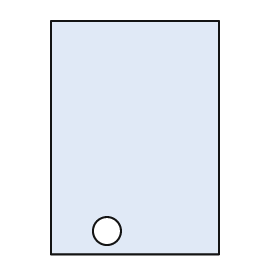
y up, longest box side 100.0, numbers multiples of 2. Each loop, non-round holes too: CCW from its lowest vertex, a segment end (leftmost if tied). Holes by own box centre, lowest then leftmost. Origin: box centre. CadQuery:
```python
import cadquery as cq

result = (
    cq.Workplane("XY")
    .moveTo(-36.0, -50.0)
    .lineTo(36.0, -50.0)
    .lineTo(36.0, 50.0)
    .lineTo(-36.0, 50.0)
    .close()
    .moveTo(-12.0, -40.0)
    .circle(6.0)
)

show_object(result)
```